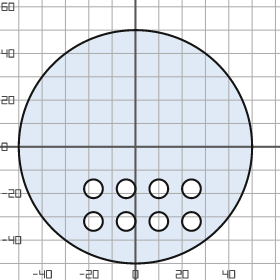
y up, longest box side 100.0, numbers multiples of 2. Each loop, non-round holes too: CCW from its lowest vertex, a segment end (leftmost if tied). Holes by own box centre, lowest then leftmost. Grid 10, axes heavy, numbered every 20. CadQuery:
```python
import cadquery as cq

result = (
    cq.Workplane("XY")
    .moveTo(0.0, 0.0)
    .circle(50.0)
    .moveTo(-18.0, -32.0)
    .circle(4.0)
    .moveTo(-4.0, -32.0)
    .circle(4.0)
    .moveTo(10.0, -32.0)
    .circle(4.0)
    .moveTo(24.0, -32.0)
    .circle(4.0)
    .moveTo(-18.0, -18.0)
    .circle(4.0)
    .moveTo(-4.0, -18.0)
    .circle(4.0)
    .moveTo(10.0, -18.0)
    .circle(4.0)
    .moveTo(24.0, -18.0)
    .circle(4.0)
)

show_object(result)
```